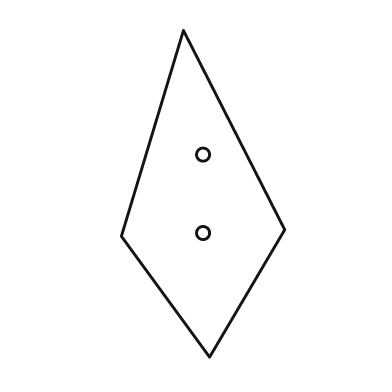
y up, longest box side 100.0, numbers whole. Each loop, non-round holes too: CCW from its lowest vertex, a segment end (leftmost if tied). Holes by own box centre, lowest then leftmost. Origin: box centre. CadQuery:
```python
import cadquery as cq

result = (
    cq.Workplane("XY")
    .moveTo(2.0, -50.0)
    .lineTo(25.0, -11.0)
    .lineTo(-6.0, 50.0)
    .lineTo(-25.0, -13.0)
    .close()
    .moveTo(0.0, -12.0)
    .circle(2.0)
    .moveTo(0.0, 12.0)
    .circle(2.0)
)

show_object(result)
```